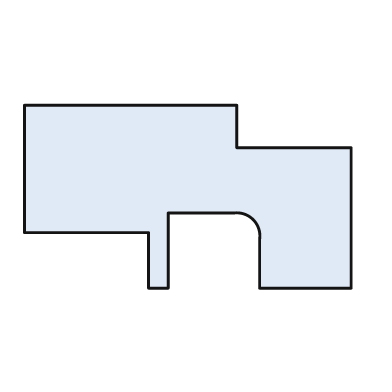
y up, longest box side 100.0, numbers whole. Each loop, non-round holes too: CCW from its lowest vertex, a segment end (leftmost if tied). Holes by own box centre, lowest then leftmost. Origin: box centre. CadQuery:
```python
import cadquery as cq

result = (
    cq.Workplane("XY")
    .moveTo(-12.0, -28.0)
    .lineTo(-6.0, -28.0)
    .lineTo(-6.0, -5.0)
    .lineTo(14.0, -5.0)
    .threePointArc((20.0, -7.0), (22.0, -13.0))
    .lineTo(22.0, -28.0)
    .lineTo(50.0, -28.0)
    .lineTo(50.0, 15.0)
    .lineTo(15.0, 15.0)
    .lineTo(15.0, 28.0)
    .lineTo(-50.0, 28.0)
    .lineTo(-50.0, -11.0)
    .lineTo(-12.0, -11.0)
    .close()
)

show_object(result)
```